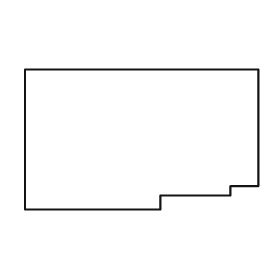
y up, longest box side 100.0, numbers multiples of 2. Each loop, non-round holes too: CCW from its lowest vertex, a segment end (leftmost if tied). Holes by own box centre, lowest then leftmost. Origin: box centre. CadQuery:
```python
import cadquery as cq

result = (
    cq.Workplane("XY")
    .moveTo(-50.0, -30.0)
    .lineTo(8.0, -30.0)
    .lineTo(8.0, -24.0)
    .lineTo(38.0, -24.0)
    .lineTo(38.0, -20.0)
    .lineTo(50.0, -20.0)
    .lineTo(50.0, 30.0)
    .lineTo(-50.0, 30.0)
    .close()
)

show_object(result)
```